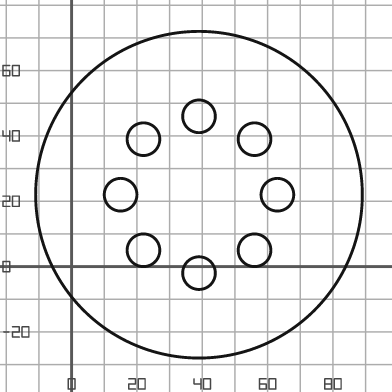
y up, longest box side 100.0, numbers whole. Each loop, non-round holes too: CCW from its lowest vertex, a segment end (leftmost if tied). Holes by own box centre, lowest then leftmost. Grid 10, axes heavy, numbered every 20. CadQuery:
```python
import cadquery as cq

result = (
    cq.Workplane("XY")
    .moveTo(39.0, 22.0)
    .circle(50.0)
    .moveTo(39.0, -2.0)
    .circle(5.0)
    .moveTo(22.0, 5.0)
    .circle(5.0)
    .moveTo(56.0, 5.0)
    .circle(5.0)
    .moveTo(15.0, 22.0)
    .circle(5.0)
    .moveTo(63.0, 22.0)
    .circle(5.0)
    .moveTo(22.0, 39.0)
    .circle(5.0)
    .moveTo(56.0, 39.0)
    .circle(5.0)
    .moveTo(39.0, 46.0)
    .circle(5.0)
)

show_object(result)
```